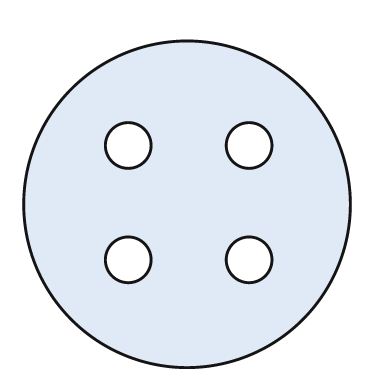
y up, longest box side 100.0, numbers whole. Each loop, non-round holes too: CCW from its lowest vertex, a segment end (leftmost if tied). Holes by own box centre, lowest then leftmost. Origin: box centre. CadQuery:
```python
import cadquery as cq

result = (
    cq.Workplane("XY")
    .moveTo(0.0, 0.0)
    .circle(50.0)
    .moveTo(-18.0, -17.0)
    .circle(7.0)
    .moveTo(19.0, -17.0)
    .circle(7.0)
    .moveTo(-18.0, 18.0)
    .circle(7.0)
    .moveTo(19.0, 18.0)
    .circle(7.0)
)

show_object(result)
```